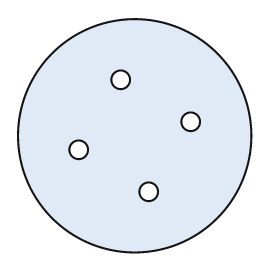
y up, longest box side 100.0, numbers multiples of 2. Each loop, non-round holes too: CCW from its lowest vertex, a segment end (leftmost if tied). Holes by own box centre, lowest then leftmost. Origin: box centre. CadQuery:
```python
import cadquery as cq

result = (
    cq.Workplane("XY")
    .moveTo(0.0, 0.0)
    .circle(50.0)
    .moveTo(6.0, -24.0)
    .circle(4.0)
    .moveTo(-24.0, -6.0)
    .circle(4.0)
    .moveTo(24.0, 6.0)
    .circle(4.0)
    .moveTo(-6.0, 24.0)
    .circle(4.0)
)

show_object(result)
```